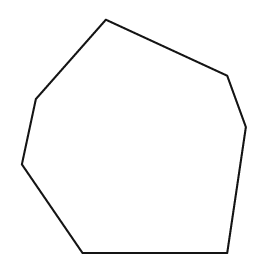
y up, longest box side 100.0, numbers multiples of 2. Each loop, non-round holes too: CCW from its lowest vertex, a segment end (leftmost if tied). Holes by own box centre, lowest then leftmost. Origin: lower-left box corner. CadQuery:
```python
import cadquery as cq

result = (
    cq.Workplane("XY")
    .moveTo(26.0, 0.0)
    .lineTo(88.0, 0.0)
    .lineTo(96.0, 54.0)
    .lineTo(88.0, 76.0)
    .lineTo(36.0, 100.0)
    .lineTo(6.0, 66.0)
    .lineTo(0.0, 38.0)
    .close()
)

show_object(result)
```